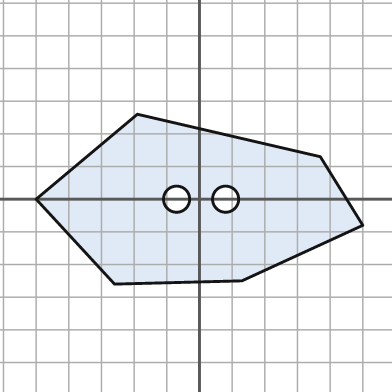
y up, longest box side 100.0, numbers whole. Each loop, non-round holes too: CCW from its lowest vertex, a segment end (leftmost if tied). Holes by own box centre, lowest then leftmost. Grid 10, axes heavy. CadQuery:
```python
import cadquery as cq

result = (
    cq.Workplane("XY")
    .moveTo(-26.0, -26.0)
    .lineTo(13.0, -25.0)
    .lineTo(50.0, -8.0)
    .lineTo(37.0, 13.0)
    .lineTo(-19.0, 26.0)
    .lineTo(-50.0, 0.0)
    .close()
    .moveTo(-7.0, 0.0)
    .circle(4.0)
    .moveTo(8.0, 0.0)
    .circle(4.0)
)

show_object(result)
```